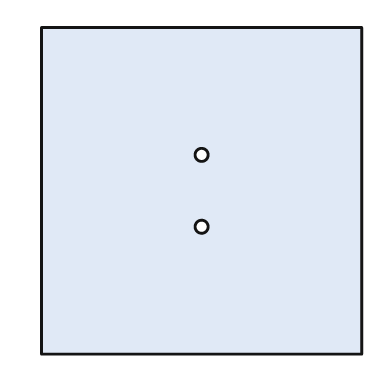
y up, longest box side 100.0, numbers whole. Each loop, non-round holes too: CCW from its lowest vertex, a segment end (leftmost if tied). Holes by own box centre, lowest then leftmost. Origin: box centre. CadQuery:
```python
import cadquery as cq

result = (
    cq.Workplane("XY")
    .moveTo(-49.0, -50.0)
    .lineTo(49.0, -50.0)
    .lineTo(49.0, 50.0)
    .lineTo(-49.0, 50.0)
    .close()
    .moveTo(0.0, -11.0)
    .circle(2.0)
    .moveTo(0.0, 11.0)
    .circle(2.0)
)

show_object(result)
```